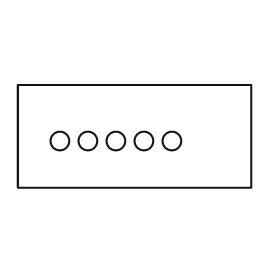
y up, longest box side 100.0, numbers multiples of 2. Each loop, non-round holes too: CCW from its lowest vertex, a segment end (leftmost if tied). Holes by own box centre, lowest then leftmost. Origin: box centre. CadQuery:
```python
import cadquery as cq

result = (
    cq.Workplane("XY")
    .moveTo(-50.0, -22.0)
    .lineTo(50.0, -22.0)
    .lineTo(50.0, 22.0)
    .lineTo(-50.0, 22.0)
    .close()
    .moveTo(-32.0, -2.0)
    .circle(4.0)
    .moveTo(-20.0, -2.0)
    .circle(4.0)
    .moveTo(-8.0, -2.0)
    .circle(4.0)
    .moveTo(4.0, -2.0)
    .circle(4.0)
    .moveTo(16.0, -2.0)
    .circle(4.0)
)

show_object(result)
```